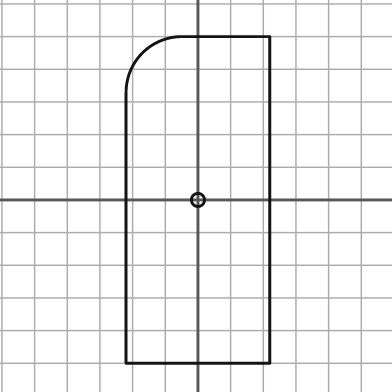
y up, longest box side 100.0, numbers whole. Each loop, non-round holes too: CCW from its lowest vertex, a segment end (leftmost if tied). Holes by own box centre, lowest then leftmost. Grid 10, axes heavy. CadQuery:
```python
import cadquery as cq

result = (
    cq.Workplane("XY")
    .moveTo(-22.0, -50.0)
    .lineTo(22.0, -50.0)
    .lineTo(22.0, 50.0)
    .lineTo(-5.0, 50.0)
    .threePointArc((-17.0, 45.0), (-22.0, 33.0))
    .close()
    .moveTo(0.0, 0.0)
    .circle(2.0)
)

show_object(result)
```